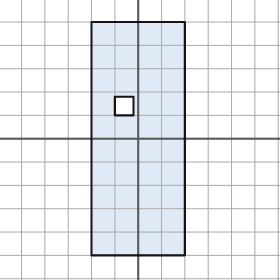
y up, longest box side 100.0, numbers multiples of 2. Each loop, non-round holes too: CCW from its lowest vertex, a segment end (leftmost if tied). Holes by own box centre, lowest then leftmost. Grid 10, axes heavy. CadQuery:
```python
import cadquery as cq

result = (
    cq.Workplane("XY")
    .moveTo(-20.0, -50.0)
    .lineTo(20.0, -50.0)
    .lineTo(20.0, 50.0)
    .lineTo(-20.0, 50.0)
    .close()
    .moveTo(-10.0, 10.0)
    .lineTo(-2.0, 10.0)
    .lineTo(-2.0, 18.0)
    .lineTo(-10.0, 18.0)
    .close()
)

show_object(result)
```